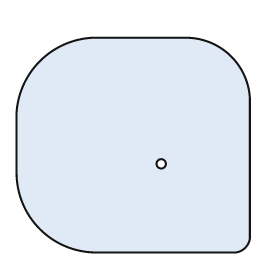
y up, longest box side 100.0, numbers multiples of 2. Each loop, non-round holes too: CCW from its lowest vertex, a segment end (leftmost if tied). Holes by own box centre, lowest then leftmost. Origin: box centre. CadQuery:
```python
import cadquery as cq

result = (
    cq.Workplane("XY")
    .moveTo(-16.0, -46.0)
    .lineTo(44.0, -46.0)
    .threePointArc((48.0, -44.0), (50.0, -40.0))
    .lineTo(50.0, 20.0)
    .threePointArc((42.0, 38.0), (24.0, 46.0))
    .lineTo(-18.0, 46.0)
    .threePointArc((-40.0, 36.0), (-50.0, 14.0))
    .lineTo(-50.0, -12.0)
    .threePointArc((-40.0, -36.0), (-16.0, -46.0))
    .close()
    .moveTo(12.0, -8.0)
    .circle(2.0)
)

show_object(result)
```